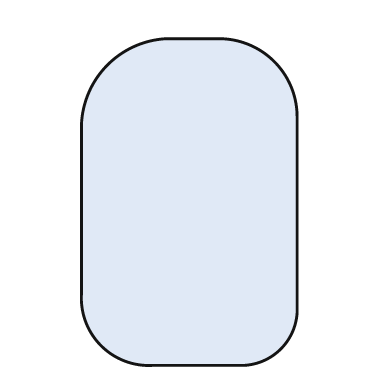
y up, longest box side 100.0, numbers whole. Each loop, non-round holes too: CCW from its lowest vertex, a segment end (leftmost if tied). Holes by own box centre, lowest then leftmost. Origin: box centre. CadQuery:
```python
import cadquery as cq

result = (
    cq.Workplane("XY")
    .moveTo(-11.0, -50.0)
    .lineTo(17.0, -50.0)
    .threePointArc((28.0, -45.0), (33.0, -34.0))
    .lineTo(33.0, 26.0)
    .threePointArc((26.0, 43.0), (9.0, 50.0))
    .lineTo(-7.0, 50.0)
    .threePointArc((-25.0, 42.0), (-33.0, 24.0))
    .lineTo(-33.0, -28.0)
    .threePointArc((-27.0, -44.0), (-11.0, -50.0))
    .close()
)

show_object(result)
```